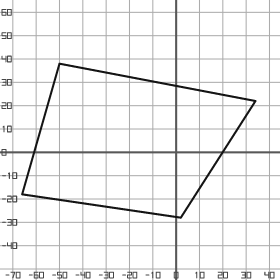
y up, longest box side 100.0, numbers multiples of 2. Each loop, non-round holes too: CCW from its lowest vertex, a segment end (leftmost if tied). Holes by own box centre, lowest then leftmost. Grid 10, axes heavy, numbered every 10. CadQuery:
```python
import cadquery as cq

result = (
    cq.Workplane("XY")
    .moveTo(2.0, -28.0)
    .lineTo(34.0, 22.0)
    .lineTo(-50.0, 38.0)
    .lineTo(-66.0, -18.0)
    .close()
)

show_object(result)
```